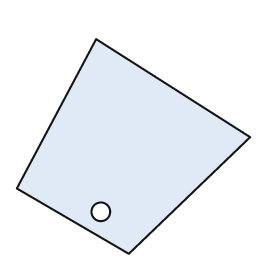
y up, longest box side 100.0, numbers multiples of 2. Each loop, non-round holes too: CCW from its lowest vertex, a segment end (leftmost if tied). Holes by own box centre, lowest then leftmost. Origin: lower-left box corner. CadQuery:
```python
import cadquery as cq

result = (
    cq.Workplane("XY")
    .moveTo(48.0, 0.0)
    .lineTo(100.0, 50.0)
    .lineTo(34.0, 92.0)
    .lineTo(0.0, 28.0)
    .close()
    .moveTo(36.0, 18.0)
    .circle(4.0)
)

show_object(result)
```